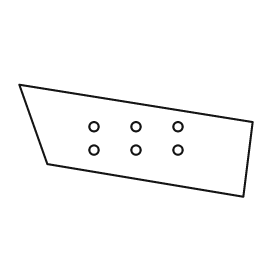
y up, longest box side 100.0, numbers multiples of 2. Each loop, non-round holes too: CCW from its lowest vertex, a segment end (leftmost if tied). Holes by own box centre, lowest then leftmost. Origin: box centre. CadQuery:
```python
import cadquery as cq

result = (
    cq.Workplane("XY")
    .moveTo(46.0, -24.0)
    .lineTo(50.0, 8.0)
    .lineTo(-50.0, 24.0)
    .lineTo(-38.0, -10.0)
    .close()
    .moveTo(-18.0, -4.0)
    .circle(2.0)
    .moveTo(0.0, -4.0)
    .circle(2.0)
    .moveTo(18.0, -4.0)
    .circle(2.0)
    .moveTo(-18.0, 6.0)
    .circle(2.0)
    .moveTo(0.0, 6.0)
    .circle(2.0)
    .moveTo(18.0, 6.0)
    .circle(2.0)
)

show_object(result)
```